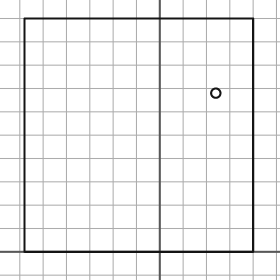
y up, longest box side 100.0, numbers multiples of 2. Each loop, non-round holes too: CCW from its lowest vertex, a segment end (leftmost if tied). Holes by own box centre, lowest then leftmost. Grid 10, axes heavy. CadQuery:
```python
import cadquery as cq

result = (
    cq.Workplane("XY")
    .moveTo(-58.0, 0.0)
    .lineTo(40.0, 0.0)
    .lineTo(40.0, 100.0)
    .lineTo(-58.0, 100.0)
    .close()
    .moveTo(24.0, 68.0)
    .circle(2.0)
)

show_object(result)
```